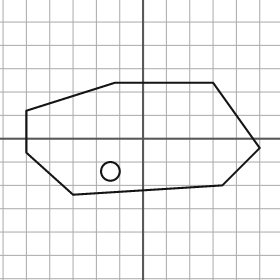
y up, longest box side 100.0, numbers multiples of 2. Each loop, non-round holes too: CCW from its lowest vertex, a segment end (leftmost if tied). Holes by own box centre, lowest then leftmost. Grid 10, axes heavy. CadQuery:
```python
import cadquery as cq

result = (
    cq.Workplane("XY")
    .moveTo(-30.0, -24.0)
    .lineTo(34.0, -20.0)
    .lineTo(50.0, -4.0)
    .lineTo(30.0, 24.0)
    .lineTo(-12.0, 24.0)
    .lineTo(-50.0, 12.0)
    .lineTo(-50.0, -6.0)
    .close()
    .moveTo(-14.0, -14.0)
    .circle(4.0)
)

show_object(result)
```